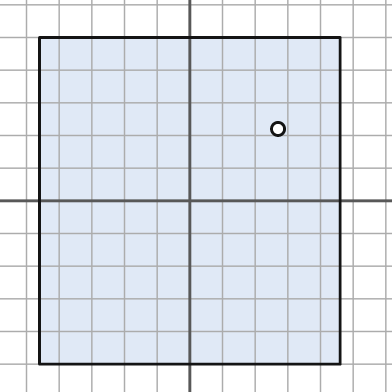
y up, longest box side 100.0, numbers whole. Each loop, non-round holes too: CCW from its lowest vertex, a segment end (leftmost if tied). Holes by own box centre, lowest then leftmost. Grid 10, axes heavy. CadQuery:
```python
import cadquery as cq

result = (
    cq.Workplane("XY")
    .moveTo(-46.0, -50.0)
    .lineTo(46.0, -50.0)
    .lineTo(46.0, 50.0)
    .lineTo(-46.0, 50.0)
    .close()
    .moveTo(27.0, 22.0)
    .circle(2.0)
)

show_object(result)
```